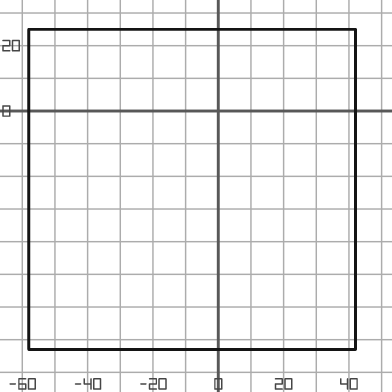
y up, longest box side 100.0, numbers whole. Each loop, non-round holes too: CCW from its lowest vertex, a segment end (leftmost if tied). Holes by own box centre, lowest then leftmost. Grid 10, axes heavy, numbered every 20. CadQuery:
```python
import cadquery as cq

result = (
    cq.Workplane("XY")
    .moveTo(-58.0, -73.0)
    .lineTo(42.0, -73.0)
    .lineTo(42.0, 25.0)
    .lineTo(-58.0, 25.0)
    .close()
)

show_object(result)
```